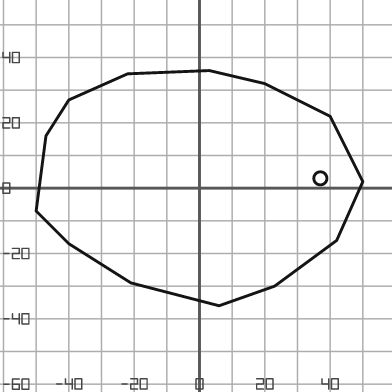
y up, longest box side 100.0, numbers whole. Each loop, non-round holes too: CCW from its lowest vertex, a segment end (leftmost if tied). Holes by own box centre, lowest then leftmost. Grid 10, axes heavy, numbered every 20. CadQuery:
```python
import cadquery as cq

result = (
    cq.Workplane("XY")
    .moveTo(6.0, -36.0)
    .lineTo(23.0, -30.0)
    .lineTo(42.0, -16.0)
    .lineTo(50.0, 2.0)
    .lineTo(40.0, 22.0)
    .lineTo(20.0, 32.0)
    .lineTo(3.0, 36.0)
    .lineTo(-22.0, 35.0)
    .lineTo(-40.0, 27.0)
    .lineTo(-47.0, 16.0)
    .lineTo(-50.0, -7.0)
    .lineTo(-40.0, -17.0)
    .lineTo(-21.0, -29.0)
    .close()
    .moveTo(37.0, 3.0)
    .circle(2.0)
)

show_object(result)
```